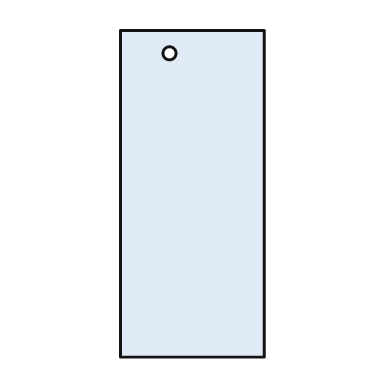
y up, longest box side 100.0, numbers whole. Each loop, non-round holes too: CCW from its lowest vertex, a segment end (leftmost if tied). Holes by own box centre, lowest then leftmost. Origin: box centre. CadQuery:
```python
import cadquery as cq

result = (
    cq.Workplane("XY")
    .moveTo(-22.0, -50.0)
    .lineTo(22.0, -50.0)
    .lineTo(22.0, 50.0)
    .lineTo(-22.0, 50.0)
    .close()
    .moveTo(-7.0, 43.0)
    .circle(2.0)
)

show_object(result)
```